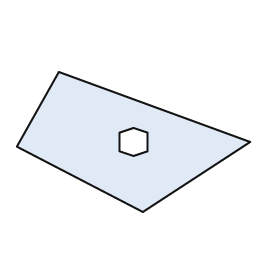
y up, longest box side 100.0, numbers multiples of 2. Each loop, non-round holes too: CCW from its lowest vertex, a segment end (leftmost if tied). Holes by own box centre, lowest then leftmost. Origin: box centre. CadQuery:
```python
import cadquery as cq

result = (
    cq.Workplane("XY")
    .moveTo(4.0, -30.0)
    .lineTo(50.0, 0.0)
    .lineTo(-32.0, 30.0)
    .lineTo(-50.0, -2.0)
    .close()
    .moveTo(0.0, -6.0)
    .lineTo(6.0, -4.0)
    .lineTo(6.0, 4.0)
    .lineTo(0.0, 6.0)
    .lineTo(-6.0, 4.0)
    .lineTo(-6.0, -4.0)
    .close()
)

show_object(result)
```